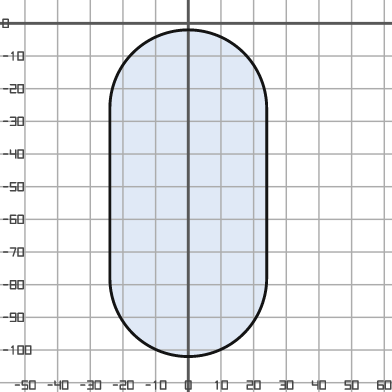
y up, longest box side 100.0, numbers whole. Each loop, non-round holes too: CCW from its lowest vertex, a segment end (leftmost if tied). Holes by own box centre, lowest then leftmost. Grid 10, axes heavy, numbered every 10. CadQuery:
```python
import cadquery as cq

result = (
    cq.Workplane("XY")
    .moveTo(-24.0, -78.0)
    .threePointArc((0.0, -102.0), (24.0, -78.0))
    .lineTo(24.0, -26.0)
    .threePointArc((0.0, -2.0), (-24.0, -26.0))
    .close()
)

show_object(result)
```